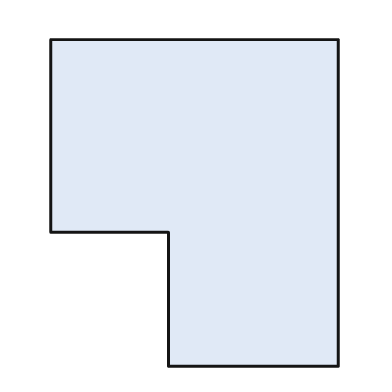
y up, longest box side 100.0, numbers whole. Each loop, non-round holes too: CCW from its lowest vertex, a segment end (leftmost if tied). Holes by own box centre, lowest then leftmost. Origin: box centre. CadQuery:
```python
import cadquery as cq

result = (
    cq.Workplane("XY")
    .moveTo(-8.0, -50.0)
    .lineTo(44.0, -50.0)
    .lineTo(44.0, 50.0)
    .lineTo(-44.0, 50.0)
    .lineTo(-44.0, -9.0)
    .lineTo(-8.0, -9.0)
    .close()
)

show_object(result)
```